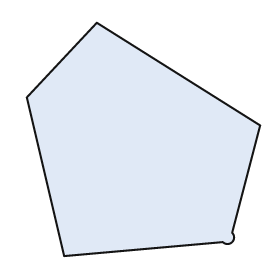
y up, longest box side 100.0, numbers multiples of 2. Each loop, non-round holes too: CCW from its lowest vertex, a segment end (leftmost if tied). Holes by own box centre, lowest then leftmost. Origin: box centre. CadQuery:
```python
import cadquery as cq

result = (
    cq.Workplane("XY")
    .moveTo(-34.0, -50.0)
    .lineTo(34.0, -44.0)
    .threePointArc((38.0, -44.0), (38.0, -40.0))
    .lineTo(50.0, 6.0)
    .lineTo(-20.0, 50.0)
    .lineTo(-50.0, 18.0)
    .close()
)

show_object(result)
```